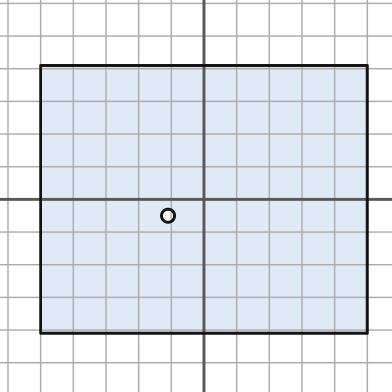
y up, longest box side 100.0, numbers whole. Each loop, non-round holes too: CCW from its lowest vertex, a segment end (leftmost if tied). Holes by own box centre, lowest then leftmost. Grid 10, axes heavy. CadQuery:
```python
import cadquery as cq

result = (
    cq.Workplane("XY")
    .moveTo(-50.0, -41.0)
    .lineTo(50.0, -41.0)
    .lineTo(50.0, 41.0)
    .lineTo(-50.0, 41.0)
    .close()
    .moveTo(-11.0, -5.0)
    .circle(2.0)
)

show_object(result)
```